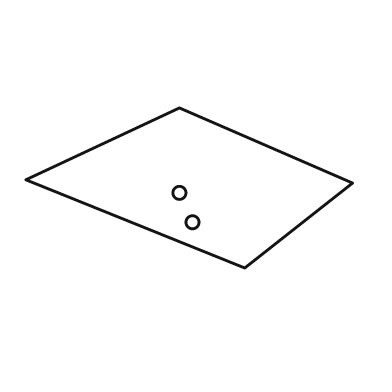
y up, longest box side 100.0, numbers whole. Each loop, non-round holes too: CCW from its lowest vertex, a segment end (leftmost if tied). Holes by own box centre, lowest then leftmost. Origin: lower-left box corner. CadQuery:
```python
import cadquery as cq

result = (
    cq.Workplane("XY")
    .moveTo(67.0, 0.0)
    .lineTo(100.0, 26.0)
    .lineTo(47.0, 49.0)
    .lineTo(0.0, 27.0)
    .close()
    .moveTo(51.0, 14.0)
    .circle(2.0)
    .moveTo(47.0, 23.0)
    .circle(2.0)
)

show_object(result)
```